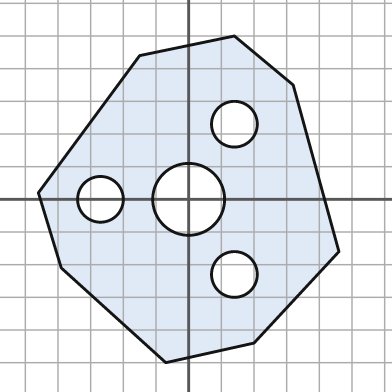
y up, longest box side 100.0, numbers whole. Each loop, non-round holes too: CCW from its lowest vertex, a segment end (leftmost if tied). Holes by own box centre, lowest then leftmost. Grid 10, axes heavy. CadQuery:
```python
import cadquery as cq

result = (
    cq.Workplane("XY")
    .moveTo(-7.0, -50.0)
    .lineTo(20.0, -44.0)
    .lineTo(46.0, -16.0)
    .lineTo(32.0, 35.0)
    .lineTo(14.0, 50.0)
    .lineTo(-15.0, 44.0)
    .lineTo(-46.0, 2.0)
    .lineTo(-39.0, -21.0)
    .close()
    .moveTo(14.0, -23.0)
    .circle(7.0)
    .moveTo(-27.0, 0.0)
    .circle(7.0)
    .moveTo(0.0, 0.0)
    .circle(11.0)
    .moveTo(14.0, 23.0)
    .circle(7.0)
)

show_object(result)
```